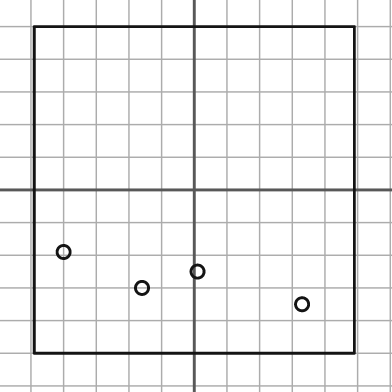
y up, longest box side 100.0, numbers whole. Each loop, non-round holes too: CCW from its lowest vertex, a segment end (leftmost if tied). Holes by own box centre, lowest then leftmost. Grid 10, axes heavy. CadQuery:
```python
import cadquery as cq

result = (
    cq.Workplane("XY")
    .moveTo(-49.0, -50.0)
    .lineTo(49.0, -50.0)
    .lineTo(49.0, 50.0)
    .lineTo(-49.0, 50.0)
    .close()
    .moveTo(33.0, -35.0)
    .circle(2.0)
    .moveTo(-16.0, -30.0)
    .circle(2.0)
    .moveTo(1.0, -25.0)
    .circle(2.0)
    .moveTo(-40.0, -19.0)
    .circle(2.0)
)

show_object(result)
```